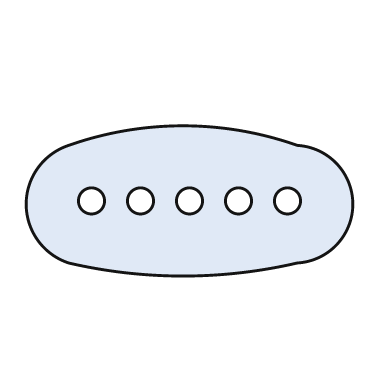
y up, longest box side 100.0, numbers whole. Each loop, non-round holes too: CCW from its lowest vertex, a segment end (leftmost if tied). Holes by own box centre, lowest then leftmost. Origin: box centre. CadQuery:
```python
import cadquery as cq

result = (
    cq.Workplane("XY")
    .moveTo(-37.0, -19.0)
    .threePointArc((-2.0, -23.0), (33.0, -19.0))
    .threePointArc((50.0, -1.0), (33.0, 17.0))
    .threePointArc((-2.0, 23.0), (-37.0, 17.0))
    .threePointArc((-50.0, -1.0), (-37.0, -19.0))
    .close()
    .moveTo(-30.0, 0.0)
    .circle(4.0)
    .moveTo(-15.0, 0.0)
    .circle(4.0)
    .moveTo(0.0, 0.0)
    .circle(4.0)
    .moveTo(15.0, 0.0)
    .circle(4.0)
    .moveTo(30.0, 0.0)
    .circle(4.0)
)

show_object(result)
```